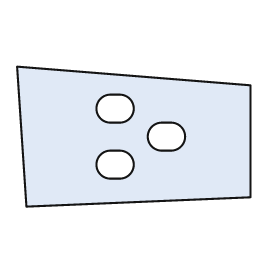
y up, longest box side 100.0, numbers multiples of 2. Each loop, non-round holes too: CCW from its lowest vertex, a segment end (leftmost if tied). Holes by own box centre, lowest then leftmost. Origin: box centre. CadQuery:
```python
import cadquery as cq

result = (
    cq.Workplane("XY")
    .moveTo(-46.0, -30.0)
    .lineTo(50.0, -26.0)
    .lineTo(50.0, 22.0)
    .lineTo(-50.0, 30.0)
    .close()
    .moveTo(-10.0, -18.0)
    .lineTo(-6.0, -18.0)
    .threePointArc((0.0, -12.0), (-6.0, -6.0))
    .lineTo(-10.0, -6.0)
    .threePointArc((-16.0, -12.0), (-10.0, -18.0))
    .close()
    .moveTo(12.0, -6.0)
    .lineTo(16.0, -6.0)
    .threePointArc((22.0, 0.0), (16.0, 6.0))
    .lineTo(12.0, 6.0)
    .threePointArc((6.0, 0.0), (12.0, -6.0))
    .close()
    .moveTo(-10.0, 6.0)
    .lineTo(-6.0, 6.0)
    .threePointArc((0.0, 12.0), (-6.0, 18.0))
    .lineTo(-10.0, 18.0)
    .threePointArc((-16.0, 12.0), (-10.0, 6.0))
    .close()
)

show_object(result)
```